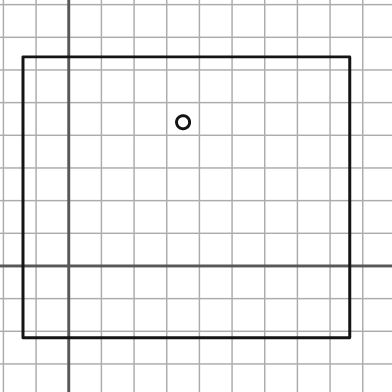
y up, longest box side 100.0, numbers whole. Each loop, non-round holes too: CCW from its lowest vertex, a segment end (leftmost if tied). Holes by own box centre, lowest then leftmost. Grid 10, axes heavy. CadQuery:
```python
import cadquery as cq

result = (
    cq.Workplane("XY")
    .moveTo(-14.0, -22.0)
    .lineTo(86.0, -22.0)
    .lineTo(86.0, 64.0)
    .lineTo(-14.0, 64.0)
    .close()
    .moveTo(35.0, 44.0)
    .circle(2.0)
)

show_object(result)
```